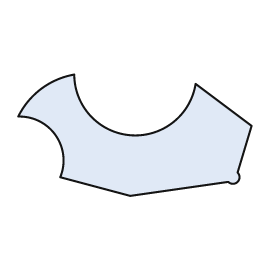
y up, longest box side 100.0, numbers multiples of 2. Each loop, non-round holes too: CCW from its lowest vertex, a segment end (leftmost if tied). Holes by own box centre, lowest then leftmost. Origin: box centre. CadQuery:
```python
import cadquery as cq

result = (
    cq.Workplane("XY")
    .moveTo(-2.0, -26.0)
    .lineTo(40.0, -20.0)
    .threePointArc((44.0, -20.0), (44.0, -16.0))
    .lineTo(50.0, 4.0)
    .lineTo(26.0, 22.0)
    .threePointArc((-2.0, 0.0), (-26.0, 26.0))
    .threePointArc((-40.0, 20.0), (-50.0, 8.0))
    .threePointArc((-34.0, 0.0), (-32.0, -18.0))
    .close()
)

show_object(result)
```